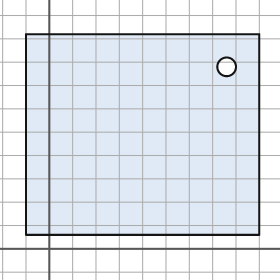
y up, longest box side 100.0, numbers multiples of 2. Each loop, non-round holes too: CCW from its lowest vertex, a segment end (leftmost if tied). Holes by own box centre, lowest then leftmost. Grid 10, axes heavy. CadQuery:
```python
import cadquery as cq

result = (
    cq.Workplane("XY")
    .moveTo(-10.0, 6.0)
    .lineTo(90.0, 6.0)
    .lineTo(90.0, 92.0)
    .lineTo(-10.0, 92.0)
    .close()
    .moveTo(76.0, 78.0)
    .circle(4.0)
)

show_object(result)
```